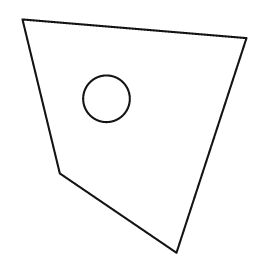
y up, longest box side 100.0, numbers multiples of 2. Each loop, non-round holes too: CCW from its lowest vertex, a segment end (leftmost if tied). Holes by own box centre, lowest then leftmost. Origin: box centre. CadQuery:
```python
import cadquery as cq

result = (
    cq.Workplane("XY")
    .moveTo(18.0, -50.0)
    .lineTo(48.0, 42.0)
    .lineTo(-48.0, 50.0)
    .lineTo(-32.0, -16.0)
    .close()
    .moveTo(-12.0, 16.0)
    .circle(10.0)
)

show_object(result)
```